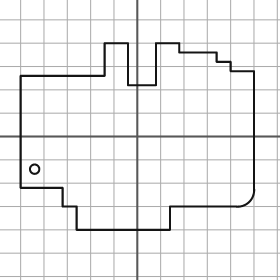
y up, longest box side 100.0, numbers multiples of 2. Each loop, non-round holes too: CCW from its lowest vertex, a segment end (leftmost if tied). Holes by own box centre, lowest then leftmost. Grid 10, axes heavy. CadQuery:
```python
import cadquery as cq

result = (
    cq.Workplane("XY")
    .moveTo(-26.0, -40.0)
    .lineTo(14.0, -40.0)
    .lineTo(14.0, -30.0)
    .lineTo(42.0, -30.0)
    .threePointArc((48.0, -28.0), (50.0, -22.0))
    .lineTo(50.0, 28.0)
    .lineTo(40.0, 28.0)
    .lineTo(40.0, 32.0)
    .lineTo(34.0, 32.0)
    .lineTo(34.0, 36.0)
    .lineTo(18.0, 36.0)
    .lineTo(18.0, 40.0)
    .lineTo(8.0, 40.0)
    .lineTo(8.0, 22.0)
    .lineTo(-4.0, 22.0)
    .lineTo(-4.0, 40.0)
    .lineTo(-14.0, 40.0)
    .lineTo(-14.0, 26.0)
    .lineTo(-50.0, 26.0)
    .lineTo(-50.0, -22.0)
    .lineTo(-32.0, -22.0)
    .lineTo(-32.0, -30.0)
    .lineTo(-26.0, -30.0)
    .close()
    .moveTo(-44.0, -14.0)
    .circle(2.0)
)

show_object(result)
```